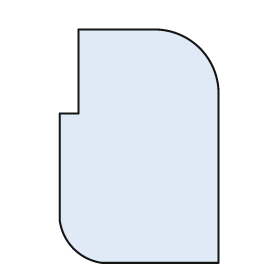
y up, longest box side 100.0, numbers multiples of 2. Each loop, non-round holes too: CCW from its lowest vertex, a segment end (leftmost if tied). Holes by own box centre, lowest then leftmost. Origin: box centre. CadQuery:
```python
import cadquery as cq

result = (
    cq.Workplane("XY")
    .moveTo(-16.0, -50.0)
    .lineTo(34.0, -50.0)
    .lineTo(34.0, 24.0)
    .threePointArc((26.0, 42.0), (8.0, 50.0))
    .lineTo(-26.0, 50.0)
    .lineTo(-26.0, 14.0)
    .lineTo(-34.0, 14.0)
    .lineTo(-34.0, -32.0)
    .threePointArc((-28.0, -44.0), (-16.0, -50.0))
    .close()
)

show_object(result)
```